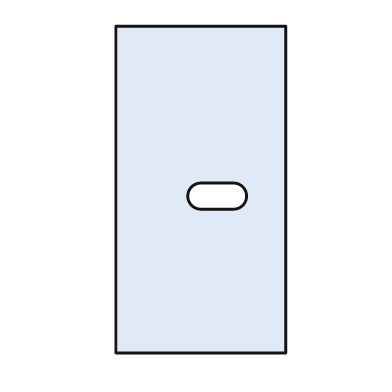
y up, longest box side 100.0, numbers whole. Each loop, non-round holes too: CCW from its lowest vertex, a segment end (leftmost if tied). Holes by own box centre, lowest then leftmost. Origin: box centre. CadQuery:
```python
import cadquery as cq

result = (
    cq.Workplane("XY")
    .moveTo(-26.0, -50.0)
    .lineTo(26.0, -50.0)
    .lineTo(26.0, 50.0)
    .lineTo(-26.0, 50.0)
    .close()
    .moveTo(0.0, -6.0)
    .lineTo(10.0, -6.0)
    .threePointArc((14.0, -2.0), (10.0, 2.0))
    .lineTo(0.0, 2.0)
    .threePointArc((-4.0, -2.0), (0.0, -6.0))
    .close()
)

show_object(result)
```